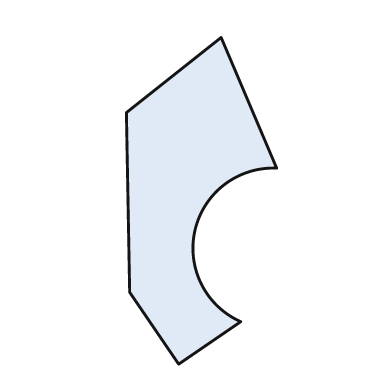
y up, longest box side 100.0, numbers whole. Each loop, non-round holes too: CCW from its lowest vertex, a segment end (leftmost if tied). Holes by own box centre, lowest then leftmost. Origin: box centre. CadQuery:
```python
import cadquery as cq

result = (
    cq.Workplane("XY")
    .moveTo(-7.0, -50.0)
    .lineTo(12.0, -37.0)
    .threePointArc((-2.0, -9.0), (23.0, 10.0))
    .lineTo(6.0, 50.0)
    .lineTo(-23.0, 27.0)
    .lineTo(-22.0, -28.0)
    .close()
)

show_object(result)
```